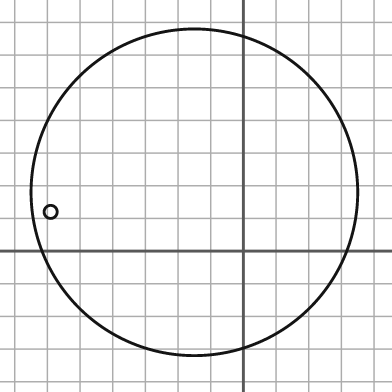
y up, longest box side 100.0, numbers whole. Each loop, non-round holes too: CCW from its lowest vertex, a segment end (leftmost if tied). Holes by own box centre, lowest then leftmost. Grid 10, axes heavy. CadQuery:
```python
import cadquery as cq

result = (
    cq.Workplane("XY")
    .moveTo(-15.0, 18.0)
    .circle(50.0)
    .moveTo(-59.0, 12.0)
    .circle(2.0)
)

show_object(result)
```